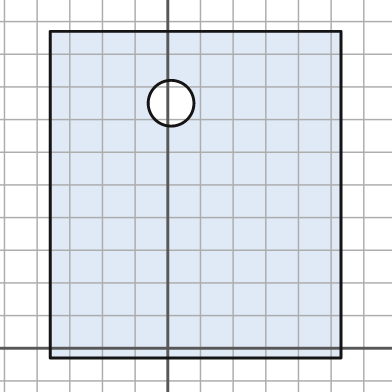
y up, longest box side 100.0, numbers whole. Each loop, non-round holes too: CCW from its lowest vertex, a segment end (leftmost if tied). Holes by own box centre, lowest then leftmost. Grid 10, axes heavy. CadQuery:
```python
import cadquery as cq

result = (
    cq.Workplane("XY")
    .moveTo(-36.0, -3.0)
    .lineTo(53.0, -3.0)
    .lineTo(53.0, 97.0)
    .lineTo(-36.0, 97.0)
    .close()
    .moveTo(1.0, 75.0)
    .circle(7.0)
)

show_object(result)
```